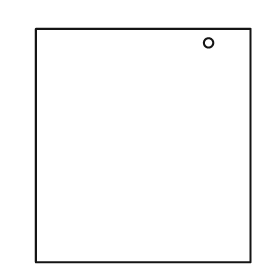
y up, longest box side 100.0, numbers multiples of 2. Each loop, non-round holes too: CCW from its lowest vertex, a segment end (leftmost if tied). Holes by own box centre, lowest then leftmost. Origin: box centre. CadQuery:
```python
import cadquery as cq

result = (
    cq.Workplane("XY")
    .moveTo(-46.0, -50.0)
    .lineTo(46.0, -50.0)
    .lineTo(46.0, 50.0)
    .lineTo(-46.0, 50.0)
    .close()
    .moveTo(28.0, 44.0)
    .circle(2.0)
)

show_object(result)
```